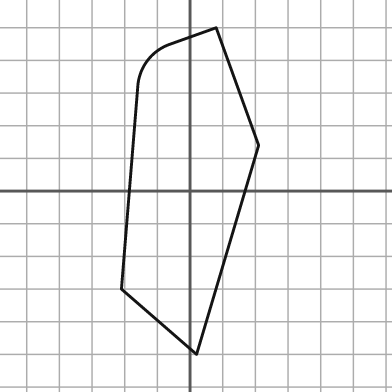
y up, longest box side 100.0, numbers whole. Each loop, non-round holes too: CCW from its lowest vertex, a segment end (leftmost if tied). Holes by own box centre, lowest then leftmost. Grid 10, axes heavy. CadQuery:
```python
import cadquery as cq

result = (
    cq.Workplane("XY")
    .moveTo(2.0, -50.0)
    .lineTo(21.0, 14.0)
    .lineTo(8.0, 50.0)
    .lineTo(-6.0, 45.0)
    .threePointArc((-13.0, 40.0), (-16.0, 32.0))
    .lineTo(-21.0, -30.0)
    .close()
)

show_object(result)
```